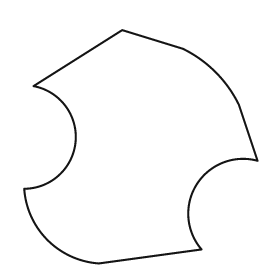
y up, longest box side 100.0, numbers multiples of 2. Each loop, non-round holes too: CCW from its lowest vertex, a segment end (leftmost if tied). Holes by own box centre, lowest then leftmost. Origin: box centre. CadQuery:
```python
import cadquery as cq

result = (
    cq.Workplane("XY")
    .moveTo(-18.0, -50.0)
    .lineTo(26.0, -44.0)
    .threePointArc((24.0, -16.0), (50.0, -6.0))
    .lineTo(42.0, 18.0)
    .threePointArc((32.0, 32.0), (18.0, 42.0))
    .lineTo(-8.0, 50.0)
    .lineTo(-46.0, 26.0)
    .threePointArc((-28.0, 2.0), (-50.0, -18.0))
    .threePointArc((-40.0, -40.0), (-18.0, -50.0))
    .close()
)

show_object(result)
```